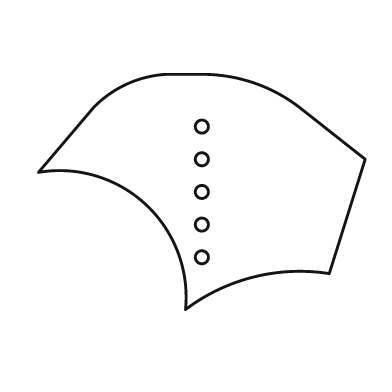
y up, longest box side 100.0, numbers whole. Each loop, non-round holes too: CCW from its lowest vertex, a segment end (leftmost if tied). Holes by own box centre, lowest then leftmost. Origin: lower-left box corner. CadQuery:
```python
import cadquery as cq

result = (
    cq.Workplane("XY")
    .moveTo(45.0, 0.0)
    .threePointArc((66.0, 10.0), (89.0, 11.0))
    .lineTo(100.0, 46.0)
    .lineTo(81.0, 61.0)
    .threePointArc((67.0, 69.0), (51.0, 72.0))
    .lineTo(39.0, 72.0)
    .threePointArc((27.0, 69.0), (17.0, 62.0))
    .lineTo(0.0, 42.0)
    .threePointArc((33.0, 32.0), (45.0, 0.0))
    .close()
    .moveTo(50.0, 16.0)
    .circle(2.0)
    .moveTo(50.0, 26.0)
    .circle(2.0)
    .moveTo(50.0, 36.0)
    .circle(2.0)
    .moveTo(50.0, 46.0)
    .circle(2.0)
    .moveTo(50.0, 56.0)
    .circle(2.0)
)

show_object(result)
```